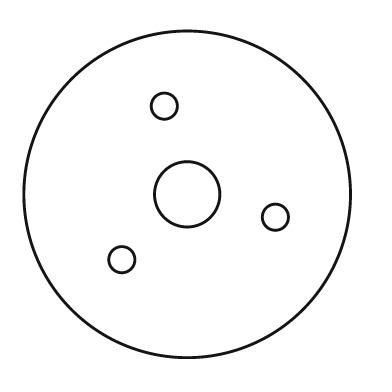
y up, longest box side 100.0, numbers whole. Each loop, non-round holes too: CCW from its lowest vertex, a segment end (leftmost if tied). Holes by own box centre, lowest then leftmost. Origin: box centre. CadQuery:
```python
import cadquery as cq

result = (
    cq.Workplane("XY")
    .moveTo(0.0, 0.0)
    .circle(50.0)
    .moveTo(-20.0, -20.0)
    .circle(4.0)
    .moveTo(27.0, -7.0)
    .circle(4.0)
    .moveTo(0.0, 0.0)
    .circle(10.0)
    .moveTo(-7.0, 27.0)
    .circle(4.0)
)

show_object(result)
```